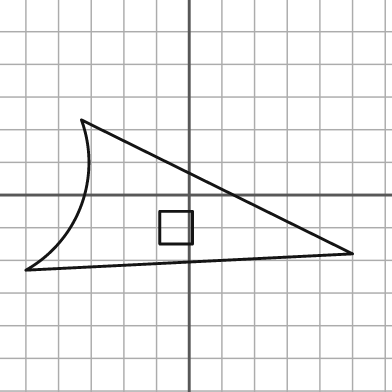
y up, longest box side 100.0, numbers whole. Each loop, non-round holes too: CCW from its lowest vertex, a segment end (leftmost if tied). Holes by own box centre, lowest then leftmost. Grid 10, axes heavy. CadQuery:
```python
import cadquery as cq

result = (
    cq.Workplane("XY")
    .moveTo(-50.0, -23.0)
    .lineTo(50.0, -18.0)
    .lineTo(-33.0, 23.0)
    .threePointArc((-33.0, -3.0), (-50.0, -23.0))
    .close()
    .moveTo(-9.0, -15.0)
    .lineTo(1.0, -15.0)
    .lineTo(1.0, -5.0)
    .lineTo(-9.0, -5.0)
    .close()
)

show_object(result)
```